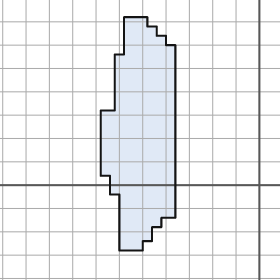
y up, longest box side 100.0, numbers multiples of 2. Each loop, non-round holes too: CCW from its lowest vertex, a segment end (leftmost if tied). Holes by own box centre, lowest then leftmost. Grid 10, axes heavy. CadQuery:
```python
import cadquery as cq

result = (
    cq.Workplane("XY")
    .moveTo(-60.0, -28.0)
    .lineTo(-50.0, -28.0)
    .lineTo(-50.0, -24.0)
    .lineTo(-46.0, -24.0)
    .lineTo(-46.0, -18.0)
    .lineTo(-42.0, -18.0)
    .lineTo(-42.0, -14.0)
    .lineTo(-36.0, -14.0)
    .lineTo(-36.0, 60.0)
    .lineTo(-40.0, 60.0)
    .lineTo(-40.0, 64.0)
    .lineTo(-44.0, 64.0)
    .lineTo(-44.0, 68.0)
    .lineTo(-48.0, 68.0)
    .lineTo(-48.0, 72.0)
    .lineTo(-58.0, 72.0)
    .lineTo(-58.0, 56.0)
    .lineTo(-62.0, 56.0)
    .lineTo(-62.0, 32.0)
    .lineTo(-68.0, 32.0)
    .lineTo(-68.0, 4.0)
    .lineTo(-64.0, 4.0)
    .lineTo(-64.0, -4.0)
    .lineTo(-60.0, -4.0)
    .close()
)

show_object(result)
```